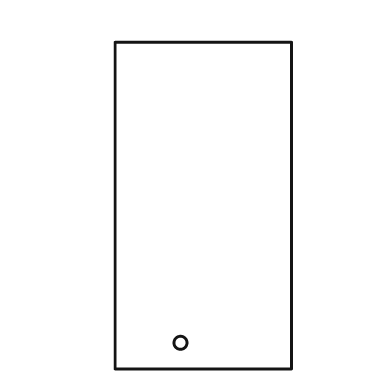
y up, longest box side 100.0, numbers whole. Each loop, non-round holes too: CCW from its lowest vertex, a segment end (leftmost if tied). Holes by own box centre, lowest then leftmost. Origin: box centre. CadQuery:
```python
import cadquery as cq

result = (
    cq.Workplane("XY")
    .moveTo(-27.0, -50.0)
    .lineTo(27.0, -50.0)
    .lineTo(27.0, 50.0)
    .lineTo(-27.0, 50.0)
    .close()
    .moveTo(-7.0, -42.0)
    .circle(2.0)
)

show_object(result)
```